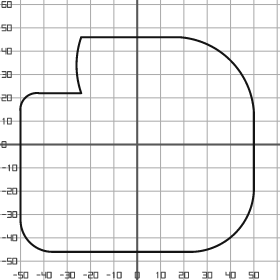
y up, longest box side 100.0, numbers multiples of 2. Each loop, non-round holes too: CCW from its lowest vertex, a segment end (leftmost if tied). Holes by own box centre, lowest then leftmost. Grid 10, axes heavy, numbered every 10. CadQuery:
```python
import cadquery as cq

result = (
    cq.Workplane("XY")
    .moveTo(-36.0, -46.0)
    .lineTo(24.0, -46.0)
    .threePointArc((42.0, -38.0), (50.0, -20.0))
    .lineTo(50.0, 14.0)
    .threePointArc((40.0, 36.0), (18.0, 46.0))
    .lineTo(-24.0, 46.0)
    .threePointArc((-26.0, 34.0), (-24.0, 22.0))
    .lineTo(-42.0, 22.0)
    .threePointArc((-48.0, 20.0), (-50.0, 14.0))
    .lineTo(-50.0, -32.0)
    .threePointArc((-46.0, -42.0), (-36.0, -46.0))
    .close()
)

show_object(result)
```